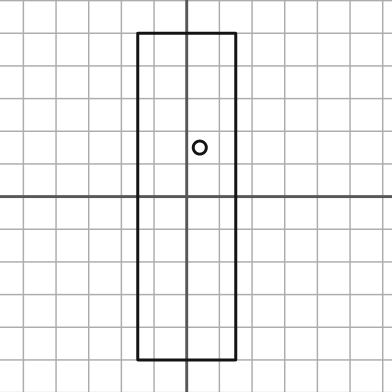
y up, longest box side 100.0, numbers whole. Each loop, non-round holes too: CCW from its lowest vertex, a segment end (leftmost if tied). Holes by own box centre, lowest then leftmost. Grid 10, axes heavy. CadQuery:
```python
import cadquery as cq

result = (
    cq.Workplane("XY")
    .moveTo(-15.0, -50.0)
    .lineTo(15.0, -50.0)
    .lineTo(15.0, 50.0)
    .lineTo(-15.0, 50.0)
    .close()
    .moveTo(4.0, 15.0)
    .circle(2.0)
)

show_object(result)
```